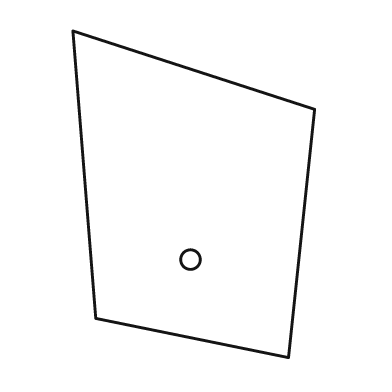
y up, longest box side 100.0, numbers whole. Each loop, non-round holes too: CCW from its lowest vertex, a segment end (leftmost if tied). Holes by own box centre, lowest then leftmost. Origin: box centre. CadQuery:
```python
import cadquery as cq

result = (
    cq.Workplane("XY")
    .moveTo(29.0, -50.0)
    .lineTo(37.0, 26.0)
    .lineTo(-37.0, 50.0)
    .lineTo(-30.0, -38.0)
    .close()
    .moveTo(-1.0, -20.0)
    .circle(3.0)
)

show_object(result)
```